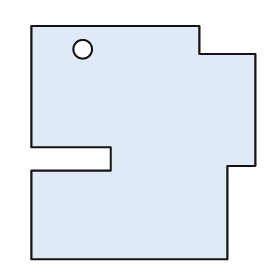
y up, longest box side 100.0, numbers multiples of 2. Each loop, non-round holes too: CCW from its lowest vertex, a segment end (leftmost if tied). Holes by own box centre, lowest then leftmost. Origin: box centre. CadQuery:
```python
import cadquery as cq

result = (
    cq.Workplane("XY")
    .moveTo(-48.0, -50.0)
    .lineTo(36.0, -50.0)
    .lineTo(36.0, -10.0)
    .lineTo(48.0, -10.0)
    .lineTo(48.0, 38.0)
    .lineTo(24.0, 38.0)
    .lineTo(24.0, 50.0)
    .lineTo(-48.0, 50.0)
    .lineTo(-48.0, -2.0)
    .lineTo(-14.0, -2.0)
    .lineTo(-14.0, -12.0)
    .lineTo(-48.0, -12.0)
    .close()
    .moveTo(-26.0, 40.0)
    .circle(4.0)
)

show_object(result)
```